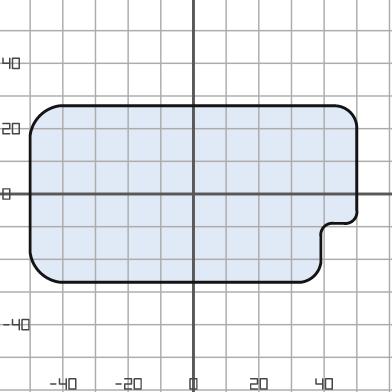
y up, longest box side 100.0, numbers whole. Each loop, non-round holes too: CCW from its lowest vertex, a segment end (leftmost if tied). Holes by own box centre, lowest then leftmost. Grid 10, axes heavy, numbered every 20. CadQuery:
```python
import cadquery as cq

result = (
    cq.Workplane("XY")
    .moveTo(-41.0, -27.0)
    .lineTo(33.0, -27.0)
    .threePointArc((37.0, -25.0), (39.0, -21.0))
    .lineTo(39.0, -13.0)
    .threePointArc((40.0, -10.0), (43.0, -9.0))
    .lineTo(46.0, -9.0)
    .threePointArc((49.0, -8.0), (50.0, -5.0))
    .lineTo(50.0, 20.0)
    .threePointArc((48.0, 25.0), (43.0, 27.0))
    .lineTo(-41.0, 27.0)
    .threePointArc((-47.0, 24.0), (-50.0, 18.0))
    .lineTo(-50.0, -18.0)
    .threePointArc((-47.0, -24.0), (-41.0, -27.0))
    .close()
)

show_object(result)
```